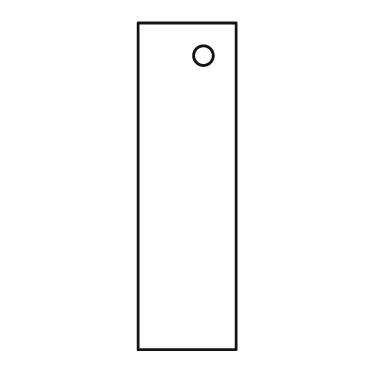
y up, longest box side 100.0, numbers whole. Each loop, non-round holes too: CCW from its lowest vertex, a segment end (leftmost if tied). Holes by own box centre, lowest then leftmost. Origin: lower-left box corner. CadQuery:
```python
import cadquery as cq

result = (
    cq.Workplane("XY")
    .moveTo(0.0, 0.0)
    .lineTo(30.0, 0.0)
    .lineTo(30.0, 100.0)
    .lineTo(0.0, 100.0)
    .close()
    .moveTo(20.0, 90.0)
    .circle(3.0)
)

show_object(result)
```